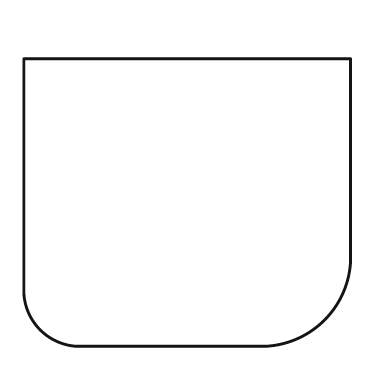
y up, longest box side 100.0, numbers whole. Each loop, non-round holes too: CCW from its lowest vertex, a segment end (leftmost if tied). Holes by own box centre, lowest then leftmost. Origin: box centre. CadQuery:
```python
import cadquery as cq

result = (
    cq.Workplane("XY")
    .moveTo(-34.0, -44.0)
    .lineTo(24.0, -44.0)
    .threePointArc((42.0, -36.0), (50.0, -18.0))
    .lineTo(50.0, 44.0)
    .lineTo(-50.0, 44.0)
    .lineTo(-50.0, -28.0)
    .threePointArc((-45.0, -39.0), (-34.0, -44.0))
    .close()
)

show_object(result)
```